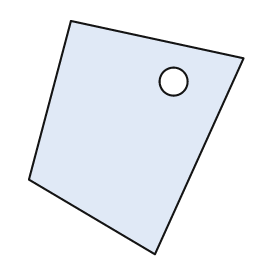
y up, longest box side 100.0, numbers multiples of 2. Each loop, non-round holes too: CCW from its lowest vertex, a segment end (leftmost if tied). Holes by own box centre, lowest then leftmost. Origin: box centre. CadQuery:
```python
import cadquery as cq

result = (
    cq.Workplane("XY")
    .moveTo(8.0, -50.0)
    .lineTo(46.0, 34.0)
    .lineTo(-28.0, 50.0)
    .lineTo(-46.0, -18.0)
    .close()
    .moveTo(16.0, 24.0)
    .circle(6.0)
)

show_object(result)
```